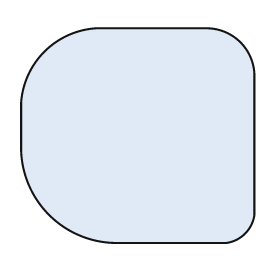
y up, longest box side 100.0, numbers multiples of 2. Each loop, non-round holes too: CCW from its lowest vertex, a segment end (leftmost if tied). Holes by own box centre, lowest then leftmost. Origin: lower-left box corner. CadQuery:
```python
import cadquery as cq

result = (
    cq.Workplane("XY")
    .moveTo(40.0, 0.0)
    .lineTo(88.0, 0.0)
    .threePointArc((96.0, 4.0), (100.0, 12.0))
    .lineTo(100.0, 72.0)
    .threePointArc((94.0, 86.0), (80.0, 92.0))
    .lineTo(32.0, 92.0)
    .threePointArc((10.0, 82.0), (0.0, 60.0))
    .lineTo(0.0, 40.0)
    .threePointArc((12.0, 12.0), (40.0, 0.0))
    .close()
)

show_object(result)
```